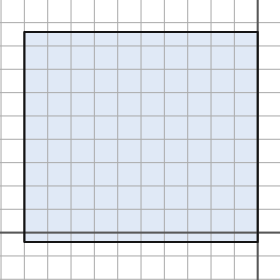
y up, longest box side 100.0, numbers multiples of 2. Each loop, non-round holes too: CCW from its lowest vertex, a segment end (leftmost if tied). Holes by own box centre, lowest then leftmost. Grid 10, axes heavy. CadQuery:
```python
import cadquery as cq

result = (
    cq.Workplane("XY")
    .moveTo(-100.0, -4.0)
    .lineTo(0.0, -4.0)
    .lineTo(0.0, 86.0)
    .lineTo(-100.0, 86.0)
    .close()
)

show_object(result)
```